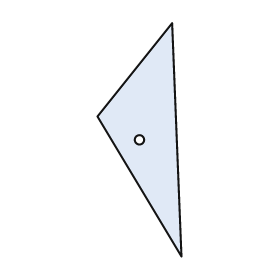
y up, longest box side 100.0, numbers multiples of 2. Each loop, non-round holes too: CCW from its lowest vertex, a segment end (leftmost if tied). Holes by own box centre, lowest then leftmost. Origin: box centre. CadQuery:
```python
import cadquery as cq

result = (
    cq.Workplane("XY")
    .moveTo(18.0, -50.0)
    .lineTo(14.0, 50.0)
    .lineTo(-18.0, 10.0)
    .close()
    .moveTo(0.0, 0.0)
    .circle(2.0)
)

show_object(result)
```